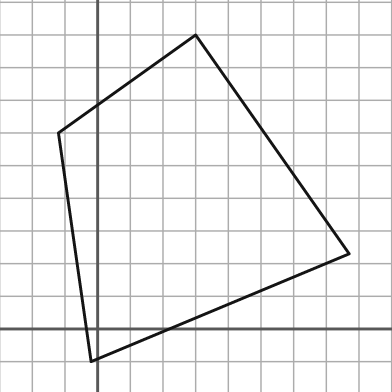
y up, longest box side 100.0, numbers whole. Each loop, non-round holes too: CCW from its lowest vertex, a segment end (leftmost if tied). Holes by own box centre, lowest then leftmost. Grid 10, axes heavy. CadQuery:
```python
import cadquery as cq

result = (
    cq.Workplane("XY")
    .moveTo(-2.0, -10.0)
    .lineTo(77.0, 23.0)
    .lineTo(30.0, 90.0)
    .lineTo(-12.0, 60.0)
    .close()
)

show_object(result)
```